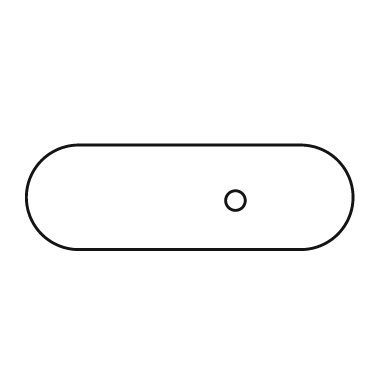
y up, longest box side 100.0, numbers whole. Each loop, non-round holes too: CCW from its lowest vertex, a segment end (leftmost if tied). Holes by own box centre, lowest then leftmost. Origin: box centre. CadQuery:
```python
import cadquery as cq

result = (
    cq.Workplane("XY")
    .moveTo(-34.0, -16.0)
    .lineTo(34.0, -16.0)
    .threePointArc((50.0, 0.0), (34.0, 16.0))
    .lineTo(-34.0, 16.0)
    .threePointArc((-50.0, 0.0), (-34.0, -16.0))
    .close()
    .moveTo(14.0, -1.0)
    .circle(3.0)
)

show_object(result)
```